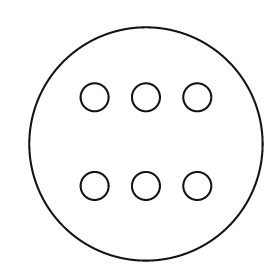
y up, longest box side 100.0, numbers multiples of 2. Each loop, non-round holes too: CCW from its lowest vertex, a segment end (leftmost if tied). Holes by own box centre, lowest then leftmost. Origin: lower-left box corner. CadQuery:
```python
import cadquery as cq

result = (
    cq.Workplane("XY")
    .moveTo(50.0, 50.0)
    .circle(50.0)
    .moveTo(28.0, 32.0)
    .circle(6.0)
    .moveTo(50.0, 32.0)
    .circle(6.0)
    .moveTo(72.0, 32.0)
    .circle(6.0)
    .moveTo(28.0, 70.0)
    .circle(6.0)
    .moveTo(50.0, 70.0)
    .circle(6.0)
    .moveTo(72.0, 70.0)
    .circle(6.0)
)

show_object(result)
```